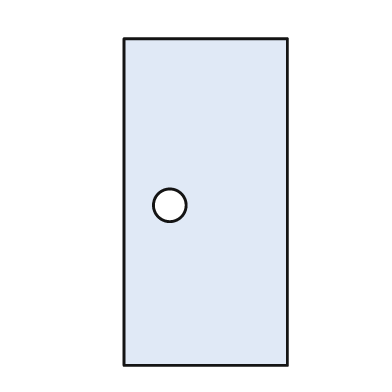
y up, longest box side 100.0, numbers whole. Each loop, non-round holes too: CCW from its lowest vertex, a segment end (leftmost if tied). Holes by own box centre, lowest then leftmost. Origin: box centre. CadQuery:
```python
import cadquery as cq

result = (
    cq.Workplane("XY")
    .moveTo(-25.0, -50.0)
    .lineTo(25.0, -50.0)
    .lineTo(25.0, 50.0)
    .lineTo(-25.0, 50.0)
    .close()
    .moveTo(-11.0, -1.0)
    .circle(5.0)
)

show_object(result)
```